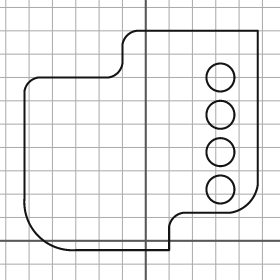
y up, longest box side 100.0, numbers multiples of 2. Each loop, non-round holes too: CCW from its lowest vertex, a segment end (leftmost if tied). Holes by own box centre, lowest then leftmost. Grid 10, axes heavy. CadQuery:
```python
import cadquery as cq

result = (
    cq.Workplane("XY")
    .moveTo(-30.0, -4.0)
    .lineTo(10.0, -4.0)
    .lineTo(10.0, 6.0)
    .threePointArc((12.0, 10.0), (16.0, 12.0))
    .lineTo(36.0, 12.0)
    .threePointArc((44.0, 16.0), (48.0, 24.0))
    .lineTo(48.0, 90.0)
    .lineTo(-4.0, 90.0)
    .threePointArc((-8.0, 88.0), (-10.0, 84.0))
    .lineTo(-10.0, 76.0)
    .threePointArc((-12.0, 72.0), (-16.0, 70.0))
    .lineTo(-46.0, 70.0)
    .threePointArc((-50.0, 68.0), (-52.0, 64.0))
    .lineTo(-52.0, 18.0)
    .threePointArc((-46.0, 2.0), (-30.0, -4.0))
    .close()
    .moveTo(32.0, 22.0)
    .circle(6.0)
    .moveTo(32.0, 38.0)
    .circle(6.0)
    .moveTo(32.0, 54.0)
    .circle(6.0)
    .moveTo(32.0, 70.0)
    .circle(6.0)
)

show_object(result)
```